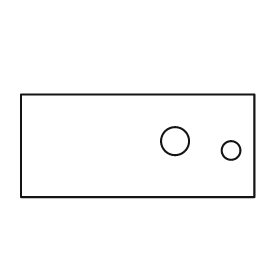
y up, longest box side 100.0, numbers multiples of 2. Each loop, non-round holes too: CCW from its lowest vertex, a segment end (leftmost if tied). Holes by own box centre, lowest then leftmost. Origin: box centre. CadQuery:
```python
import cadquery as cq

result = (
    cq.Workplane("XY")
    .moveTo(-50.0, -22.0)
    .lineTo(50.0, -22.0)
    .lineTo(50.0, 22.0)
    .lineTo(-50.0, 22.0)
    .close()
    .moveTo(40.0, -2.0)
    .circle(4.0)
    .moveTo(16.0, 2.0)
    .circle(6.0)
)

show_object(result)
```